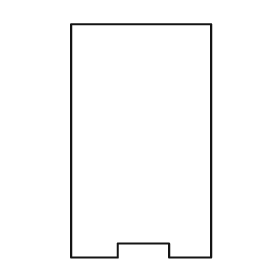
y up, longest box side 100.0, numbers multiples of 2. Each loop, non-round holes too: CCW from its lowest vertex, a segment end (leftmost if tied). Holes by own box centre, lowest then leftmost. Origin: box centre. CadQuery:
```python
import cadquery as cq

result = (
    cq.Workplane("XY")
    .moveTo(-30.0, -50.0)
    .lineTo(-10.0, -50.0)
    .lineTo(-10.0, -44.0)
    .lineTo(12.0, -44.0)
    .lineTo(12.0, -50.0)
    .lineTo(30.0, -50.0)
    .lineTo(30.0, 50.0)
    .lineTo(-30.0, 50.0)
    .close()
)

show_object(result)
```